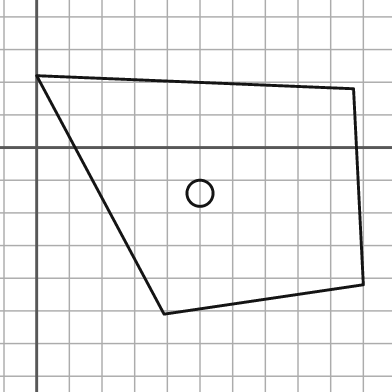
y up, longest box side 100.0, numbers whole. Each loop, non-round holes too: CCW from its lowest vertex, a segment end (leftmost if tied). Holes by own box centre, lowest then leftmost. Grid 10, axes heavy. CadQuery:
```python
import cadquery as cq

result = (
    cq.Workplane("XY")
    .moveTo(39.0, -51.0)
    .lineTo(100.0, -42.0)
    .lineTo(97.0, 18.0)
    .lineTo(0.0, 22.0)
    .close()
    .moveTo(50.0, -14.0)
    .circle(4.0)
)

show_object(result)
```